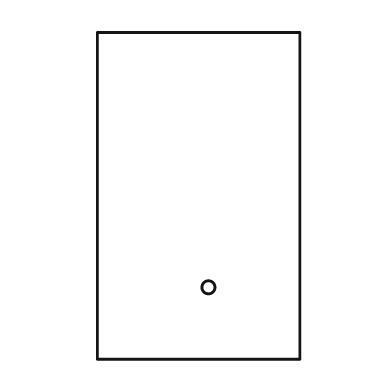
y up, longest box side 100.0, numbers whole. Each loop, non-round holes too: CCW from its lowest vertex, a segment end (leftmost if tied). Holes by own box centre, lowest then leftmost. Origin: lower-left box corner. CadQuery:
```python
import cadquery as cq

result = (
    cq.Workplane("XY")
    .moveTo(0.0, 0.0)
    .lineTo(62.0, 0.0)
    .lineTo(62.0, 100.0)
    .lineTo(0.0, 100.0)
    .close()
    .moveTo(34.0, 22.0)
    .circle(2.0)
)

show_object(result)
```